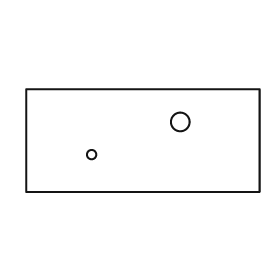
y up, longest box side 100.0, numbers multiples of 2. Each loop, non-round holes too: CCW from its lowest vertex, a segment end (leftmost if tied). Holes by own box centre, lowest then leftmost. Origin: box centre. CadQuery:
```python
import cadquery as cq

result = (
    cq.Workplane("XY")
    .moveTo(-50.0, -22.0)
    .lineTo(50.0, -22.0)
    .lineTo(50.0, 22.0)
    .lineTo(-50.0, 22.0)
    .close()
    .moveTo(-22.0, -6.0)
    .circle(2.0)
    .moveTo(16.0, 8.0)
    .circle(4.0)
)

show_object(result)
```